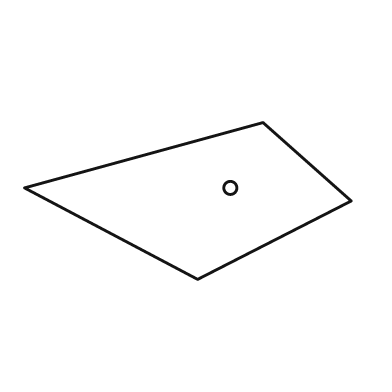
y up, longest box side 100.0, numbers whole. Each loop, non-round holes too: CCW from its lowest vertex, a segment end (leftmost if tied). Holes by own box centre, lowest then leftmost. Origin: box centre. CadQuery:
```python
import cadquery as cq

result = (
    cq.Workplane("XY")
    .moveTo(3.0, -24.0)
    .lineTo(50.0, 0.0)
    .lineTo(23.0, 24.0)
    .lineTo(-50.0, 4.0)
    .close()
    .moveTo(13.0, 4.0)
    .circle(2.0)
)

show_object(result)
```